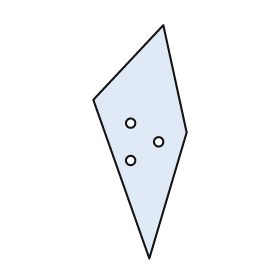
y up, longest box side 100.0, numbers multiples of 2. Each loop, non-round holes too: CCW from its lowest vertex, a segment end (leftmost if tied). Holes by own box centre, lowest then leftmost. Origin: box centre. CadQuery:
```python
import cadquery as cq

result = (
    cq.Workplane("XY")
    .moveTo(4.0, -50.0)
    .lineTo(20.0, 4.0)
    .lineTo(10.0, 50.0)
    .lineTo(-20.0, 18.0)
    .close()
    .moveTo(-4.0, -8.0)
    .circle(2.0)
    .moveTo(8.0, 0.0)
    .circle(2.0)
    .moveTo(-4.0, 8.0)
    .circle(2.0)
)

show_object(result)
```